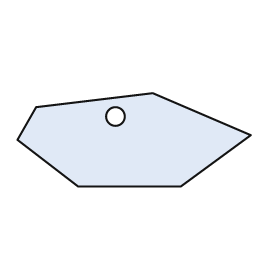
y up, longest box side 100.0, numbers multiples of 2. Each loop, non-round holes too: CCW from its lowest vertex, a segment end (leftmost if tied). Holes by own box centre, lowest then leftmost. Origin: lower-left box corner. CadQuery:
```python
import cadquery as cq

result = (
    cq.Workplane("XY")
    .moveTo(26.0, 0.0)
    .lineTo(70.0, 0.0)
    .lineTo(100.0, 22.0)
    .lineTo(58.0, 40.0)
    .lineTo(8.0, 34.0)
    .lineTo(0.0, 20.0)
    .close()
    .moveTo(42.0, 30.0)
    .circle(4.0)
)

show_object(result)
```